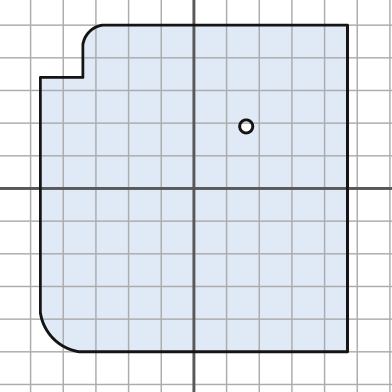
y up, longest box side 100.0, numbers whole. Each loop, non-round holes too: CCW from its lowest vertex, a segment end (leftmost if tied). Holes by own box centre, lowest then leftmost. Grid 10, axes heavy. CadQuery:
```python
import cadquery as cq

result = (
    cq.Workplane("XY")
    .moveTo(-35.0, -50.0)
    .lineTo(47.0, -50.0)
    .lineTo(47.0, 50.0)
    .lineTo(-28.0, 50.0)
    .threePointArc((-32.0, 48.0), (-34.0, 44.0))
    .lineTo(-34.0, 34.0)
    .lineTo(-47.0, 34.0)
    .lineTo(-47.0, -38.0)
    .threePointArc((-43.0, -46.0), (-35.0, -50.0))
    .close()
    .moveTo(16.0, 19.0)
    .circle(2.0)
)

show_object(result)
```